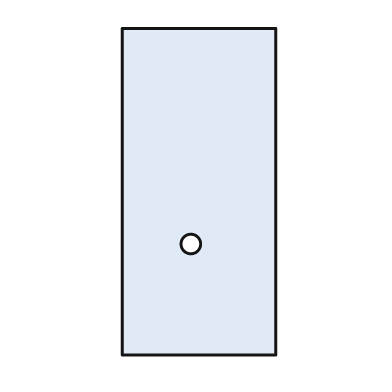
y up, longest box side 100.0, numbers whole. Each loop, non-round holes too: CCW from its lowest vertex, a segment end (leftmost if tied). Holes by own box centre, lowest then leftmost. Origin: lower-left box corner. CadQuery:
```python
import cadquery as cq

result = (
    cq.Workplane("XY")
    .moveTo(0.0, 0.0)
    .lineTo(47.0, 0.0)
    .lineTo(47.0, 100.0)
    .lineTo(0.0, 100.0)
    .close()
    .moveTo(21.0, 34.0)
    .circle(3.0)
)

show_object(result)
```